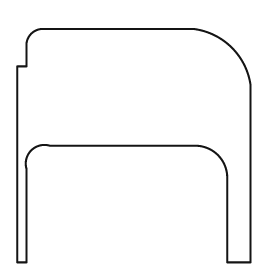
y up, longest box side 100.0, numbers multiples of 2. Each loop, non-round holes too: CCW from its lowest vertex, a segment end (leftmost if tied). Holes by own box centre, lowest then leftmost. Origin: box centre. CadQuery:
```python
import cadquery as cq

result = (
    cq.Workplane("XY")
    .moveTo(-50.0, -50.0)
    .lineTo(-46.0, -50.0)
    .lineTo(-46.0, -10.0)
    .threePointArc((-44.0, -2.0), (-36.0, 0.0))
    .lineTo(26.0, 0.0)
    .threePointArc((36.0, -4.0), (40.0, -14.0))
    .lineTo(40.0, -50.0)
    .lineTo(50.0, -50.0)
    .lineTo(50.0, 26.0)
    .threePointArc((42.0, 42.0), (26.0, 50.0))
    .lineTo(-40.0, 50.0)
    .threePointArc((-44.0, 48.0), (-46.0, 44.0))
    .lineTo(-46.0, 34.0)
    .lineTo(-50.0, 34.0)
    .close()
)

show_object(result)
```